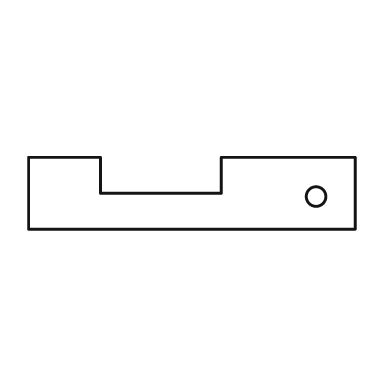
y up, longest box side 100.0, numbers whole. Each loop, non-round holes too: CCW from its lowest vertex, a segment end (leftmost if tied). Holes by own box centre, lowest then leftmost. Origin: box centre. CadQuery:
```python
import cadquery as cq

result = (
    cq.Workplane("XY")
    .moveTo(-50.0, -11.0)
    .lineTo(50.0, -11.0)
    .lineTo(50.0, 11.0)
    .lineTo(9.0, 11.0)
    .lineTo(9.0, 0.0)
    .lineTo(-28.0, 0.0)
    .lineTo(-28.0, 11.0)
    .lineTo(-50.0, 11.0)
    .close()
    .moveTo(38.0, -1.0)
    .circle(3.0)
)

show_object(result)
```